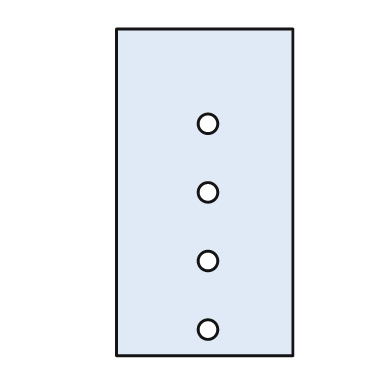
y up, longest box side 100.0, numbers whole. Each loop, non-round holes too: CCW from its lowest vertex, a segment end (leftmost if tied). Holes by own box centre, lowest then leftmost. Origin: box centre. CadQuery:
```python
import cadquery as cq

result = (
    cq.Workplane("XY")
    .moveTo(-27.0, -50.0)
    .lineTo(27.0, -50.0)
    .lineTo(27.0, 50.0)
    .lineTo(-27.0, 50.0)
    .close()
    .moveTo(1.0, -42.0)
    .circle(3.0)
    .moveTo(1.0, -21.0)
    .circle(3.0)
    .moveTo(1.0, 0.0)
    .circle(3.0)
    .moveTo(1.0, 21.0)
    .circle(3.0)
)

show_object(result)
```